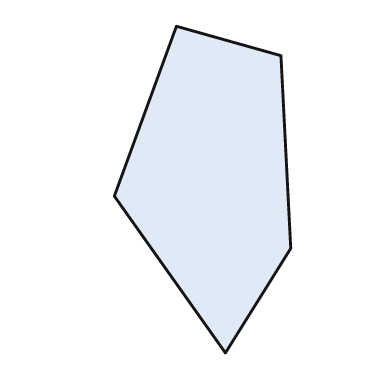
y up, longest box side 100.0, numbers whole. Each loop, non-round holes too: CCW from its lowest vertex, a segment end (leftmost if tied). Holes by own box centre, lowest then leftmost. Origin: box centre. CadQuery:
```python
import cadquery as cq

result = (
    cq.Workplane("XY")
    .moveTo(7.0, -50.0)
    .lineTo(27.0, -18.0)
    .lineTo(24.0, 41.0)
    .lineTo(-8.0, 50.0)
    .lineTo(-27.0, -2.0)
    .close()
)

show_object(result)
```